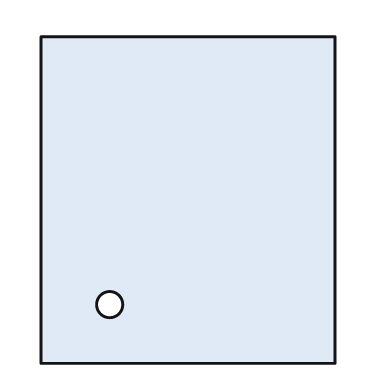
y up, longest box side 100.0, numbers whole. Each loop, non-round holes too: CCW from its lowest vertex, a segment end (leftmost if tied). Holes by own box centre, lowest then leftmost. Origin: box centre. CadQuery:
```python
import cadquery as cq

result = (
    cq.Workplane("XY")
    .moveTo(-45.0, -50.0)
    .lineTo(45.0, -50.0)
    .lineTo(45.0, 50.0)
    .lineTo(-45.0, 50.0)
    .close()
    .moveTo(-24.0, -32.0)
    .circle(4.0)
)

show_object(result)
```